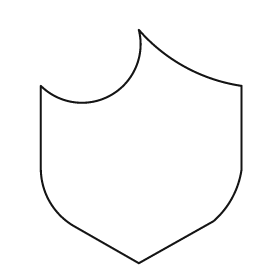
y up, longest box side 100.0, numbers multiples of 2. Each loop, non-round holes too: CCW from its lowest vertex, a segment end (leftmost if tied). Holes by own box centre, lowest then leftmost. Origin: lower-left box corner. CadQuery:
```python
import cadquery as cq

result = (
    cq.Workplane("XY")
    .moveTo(42.0, 0.0)
    .lineTo(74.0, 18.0)
    .threePointArc((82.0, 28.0), (86.0, 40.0))
    .lineTo(86.0, 76.0)
    .threePointArc((62.0, 84.0), (42.0, 100.0))
    .threePointArc((30.0, 72.0), (0.0, 76.0))
    .lineTo(0.0, 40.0)
    .threePointArc((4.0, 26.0), (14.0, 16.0))
    .close()
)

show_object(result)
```